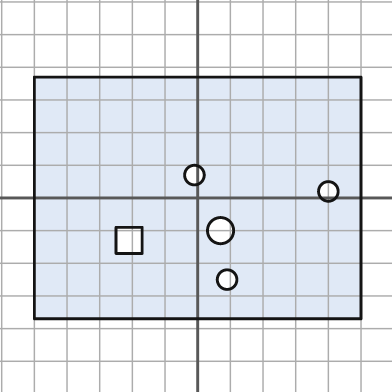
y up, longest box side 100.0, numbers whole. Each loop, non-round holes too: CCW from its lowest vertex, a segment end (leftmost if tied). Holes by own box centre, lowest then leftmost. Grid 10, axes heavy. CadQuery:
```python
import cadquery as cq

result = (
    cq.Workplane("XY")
    .moveTo(-50.0, -37.0)
    .lineTo(50.0, -37.0)
    .lineTo(50.0, 37.0)
    .lineTo(-50.0, 37.0)
    .close()
    .moveTo(9.0, -25.0)
    .circle(3.0)
    .moveTo(-25.0, -17.0)
    .lineTo(-17.0, -17.0)
    .lineTo(-17.0, -9.0)
    .lineTo(-25.0, -9.0)
    .close()
    .moveTo(7.0, -10.0)
    .circle(4.0)
    .moveTo(40.0, 2.0)
    .circle(3.0)
    .moveTo(-1.0, 7.0)
    .circle(3.0)
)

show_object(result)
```